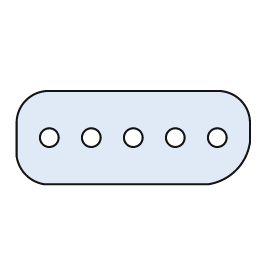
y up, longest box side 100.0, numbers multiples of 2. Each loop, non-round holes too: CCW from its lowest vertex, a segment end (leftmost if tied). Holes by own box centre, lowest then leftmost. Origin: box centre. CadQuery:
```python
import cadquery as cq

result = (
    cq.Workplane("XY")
    .moveTo(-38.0, -20.0)
    .lineTo(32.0, -20.0)
    .threePointArc((44.0, -14.0), (50.0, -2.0))
    .lineTo(50.0, 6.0)
    .threePointArc((46.0, 16.0), (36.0, 20.0))
    .lineTo(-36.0, 20.0)
    .threePointArc((-46.0, 16.0), (-50.0, 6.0))
    .lineTo(-50.0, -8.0)
    .threePointArc((-46.0, -16.0), (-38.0, -20.0))
    .close()
    .moveTo(-36.0, 0.0)
    .circle(4.0)
    .moveTo(-18.0, 0.0)
    .circle(4.0)
    .moveTo(0.0, 0.0)
    .circle(4.0)
    .moveTo(18.0, 0.0)
    .circle(4.0)
    .moveTo(36.0, 0.0)
    .circle(4.0)
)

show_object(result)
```